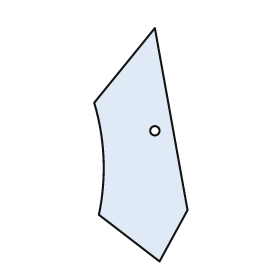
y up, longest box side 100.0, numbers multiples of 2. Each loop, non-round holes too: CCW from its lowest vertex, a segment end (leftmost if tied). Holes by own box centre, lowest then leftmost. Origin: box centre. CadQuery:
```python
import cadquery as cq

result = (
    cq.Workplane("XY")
    .moveTo(8.0, -50.0)
    .lineTo(20.0, -28.0)
    .lineTo(6.0, 50.0)
    .lineTo(-20.0, 18.0)
    .threePointArc((-16.0, -6.0), (-18.0, -30.0))
    .close()
    .moveTo(6.0, 6.0)
    .circle(2.0)
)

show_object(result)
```